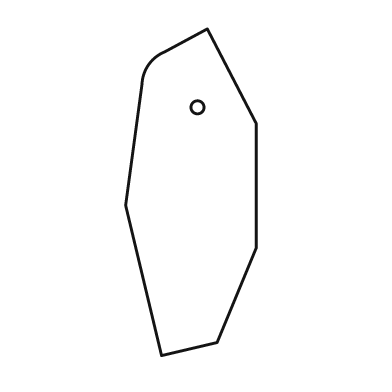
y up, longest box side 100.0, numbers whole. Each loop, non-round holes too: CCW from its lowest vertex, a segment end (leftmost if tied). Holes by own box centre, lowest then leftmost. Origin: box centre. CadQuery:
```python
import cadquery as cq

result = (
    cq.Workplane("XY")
    .moveTo(-9.0, -50.0)
    .lineTo(8.0, -46.0)
    .lineTo(20.0, -17.0)
    .lineTo(20.0, 21.0)
    .lineTo(5.0, 50.0)
    .lineTo(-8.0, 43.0)
    .threePointArc((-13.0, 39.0), (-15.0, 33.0))
    .lineTo(-20.0, -4.0)
    .close()
    .moveTo(2.0, 26.0)
    .circle(2.0)
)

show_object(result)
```